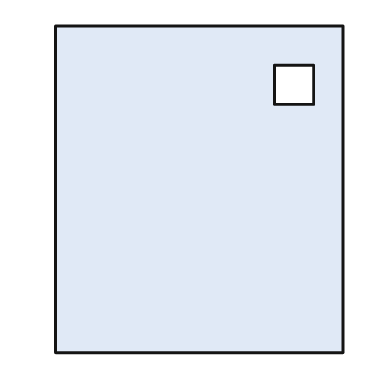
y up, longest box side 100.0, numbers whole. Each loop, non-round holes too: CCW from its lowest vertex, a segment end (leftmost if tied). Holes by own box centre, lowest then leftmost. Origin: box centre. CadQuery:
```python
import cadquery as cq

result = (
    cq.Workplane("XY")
    .moveTo(-44.0, -50.0)
    .lineTo(44.0, -50.0)
    .lineTo(44.0, 50.0)
    .lineTo(-44.0, 50.0)
    .close()
    .moveTo(23.0, 26.0)
    .lineTo(35.0, 26.0)
    .lineTo(35.0, 38.0)
    .lineTo(23.0, 38.0)
    .close()
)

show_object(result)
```